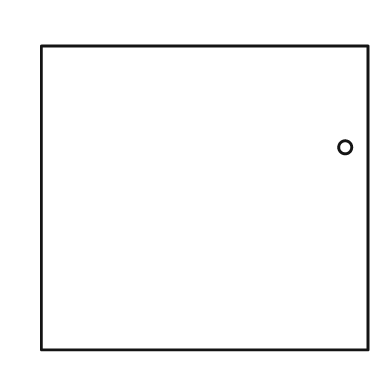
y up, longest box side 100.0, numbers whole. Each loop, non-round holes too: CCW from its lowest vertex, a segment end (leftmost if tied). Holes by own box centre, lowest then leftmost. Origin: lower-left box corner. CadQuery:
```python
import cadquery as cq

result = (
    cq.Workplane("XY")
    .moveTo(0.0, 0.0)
    .lineTo(100.0, 0.0)
    .lineTo(100.0, 93.0)
    .lineTo(0.0, 93.0)
    .close()
    .moveTo(93.0, 62.0)
    .circle(2.0)
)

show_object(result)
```